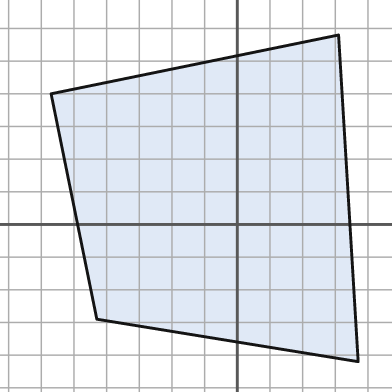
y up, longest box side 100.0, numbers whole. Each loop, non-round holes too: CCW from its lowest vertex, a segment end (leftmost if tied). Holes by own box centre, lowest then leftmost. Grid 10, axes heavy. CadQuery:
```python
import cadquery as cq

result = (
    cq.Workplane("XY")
    .moveTo(37.0, -42.0)
    .lineTo(31.0, 58.0)
    .lineTo(-57.0, 40.0)
    .lineTo(-43.0, -29.0)
    .close()
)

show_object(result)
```